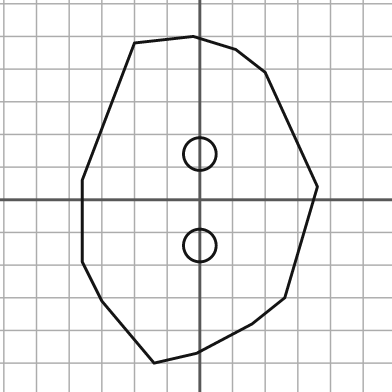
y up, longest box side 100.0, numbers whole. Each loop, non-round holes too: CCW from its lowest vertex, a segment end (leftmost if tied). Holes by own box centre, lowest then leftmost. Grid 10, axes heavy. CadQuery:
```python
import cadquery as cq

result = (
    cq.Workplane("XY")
    .moveTo(-14.0, -50.0)
    .lineTo(-1.0, -47.0)
    .lineTo(16.0, -38.0)
    .lineTo(26.0, -30.0)
    .lineTo(36.0, 4.0)
    .lineTo(20.0, 39.0)
    .lineTo(11.0, 46.0)
    .lineTo(-2.0, 50.0)
    .lineTo(-20.0, 48.0)
    .lineTo(-36.0, 6.0)
    .lineTo(-36.0, -19.0)
    .lineTo(-30.0, -31.0)
    .close()
    .moveTo(0.0, -14.0)
    .circle(5.0)
    .moveTo(0.0, 14.0)
    .circle(5.0)
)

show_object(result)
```